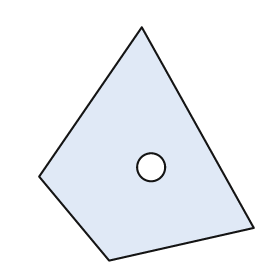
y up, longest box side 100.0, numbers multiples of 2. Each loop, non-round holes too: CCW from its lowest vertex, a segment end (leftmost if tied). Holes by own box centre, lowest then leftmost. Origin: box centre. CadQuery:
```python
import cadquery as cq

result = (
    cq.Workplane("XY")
    .moveTo(-16.0, -50.0)
    .lineTo(46.0, -36.0)
    .lineTo(-2.0, 50.0)
    .lineTo(-46.0, -14.0)
    .close()
    .moveTo(2.0, -10.0)
    .circle(6.0)
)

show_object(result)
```